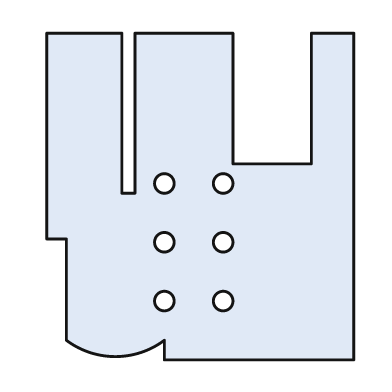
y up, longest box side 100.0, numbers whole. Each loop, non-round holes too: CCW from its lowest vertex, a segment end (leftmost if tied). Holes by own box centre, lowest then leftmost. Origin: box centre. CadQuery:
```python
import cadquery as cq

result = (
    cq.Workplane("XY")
    .moveTo(-11.0, -50.0)
    .lineTo(47.0, -50.0)
    .lineTo(47.0, 50.0)
    .lineTo(34.0, 50.0)
    .lineTo(34.0, 10.0)
    .lineTo(10.0, 10.0)
    .lineTo(10.0, 50.0)
    .lineTo(-20.0, 50.0)
    .lineTo(-20.0, 1.0)
    .lineTo(-24.0, 1.0)
    .lineTo(-24.0, 50.0)
    .lineTo(-47.0, 50.0)
    .lineTo(-47.0, -13.0)
    .lineTo(-41.0, -13.0)
    .lineTo(-41.0, -44.0)
    .threePointArc((-26.0, -49.0), (-11.0, -44.0))
    .close()
    .moveTo(-11.0, -32.0)
    .circle(3.0)
    .moveTo(7.0, -32.0)
    .circle(3.0)
    .moveTo(-11.0, -14.0)
    .circle(3.0)
    .moveTo(7.0, -14.0)
    .circle(3.0)
    .moveTo(-11.0, 4.0)
    .circle(3.0)
    .moveTo(7.0, 4.0)
    .circle(3.0)
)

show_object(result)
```